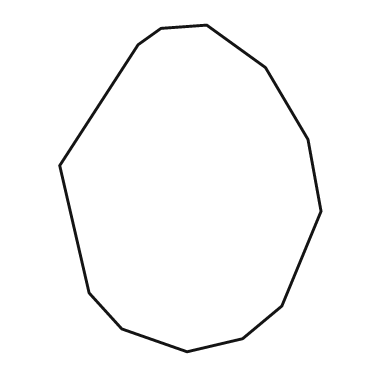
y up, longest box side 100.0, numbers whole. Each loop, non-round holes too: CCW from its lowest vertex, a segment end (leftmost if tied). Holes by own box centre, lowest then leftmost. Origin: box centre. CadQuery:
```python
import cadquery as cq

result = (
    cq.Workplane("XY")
    .moveTo(-1.0, -50.0)
    .lineTo(16.0, -46.0)
    .lineTo(28.0, -36.0)
    .lineTo(40.0, -7.0)
    .lineTo(36.0, 15.0)
    .lineTo(23.0, 37.0)
    .lineTo(5.0, 50.0)
    .lineTo(-9.0, 49.0)
    .lineTo(-16.0, 44.0)
    .lineTo(-40.0, 7.0)
    .lineTo(-31.0, -32.0)
    .lineTo(-21.0, -43.0)
    .close()
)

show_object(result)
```